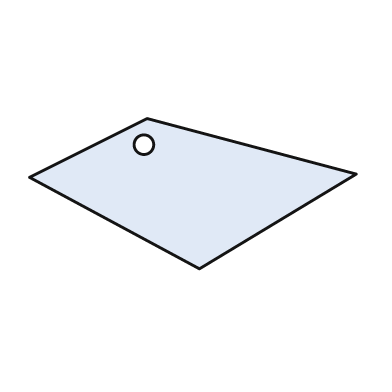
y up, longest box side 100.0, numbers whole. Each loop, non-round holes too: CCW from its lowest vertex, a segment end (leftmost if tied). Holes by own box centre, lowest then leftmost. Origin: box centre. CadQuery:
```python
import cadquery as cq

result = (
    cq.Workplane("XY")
    .moveTo(2.0, -23.0)
    .lineTo(50.0, 6.0)
    .lineTo(-14.0, 23.0)
    .lineTo(-50.0, 5.0)
    .close()
    .moveTo(-15.0, 15.0)
    .circle(3.0)
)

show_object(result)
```